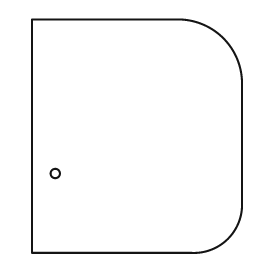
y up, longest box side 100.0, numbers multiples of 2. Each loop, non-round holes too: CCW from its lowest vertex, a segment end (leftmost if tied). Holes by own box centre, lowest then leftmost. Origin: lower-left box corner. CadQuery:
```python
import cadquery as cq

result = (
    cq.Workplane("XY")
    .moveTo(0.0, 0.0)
    .lineTo(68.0, 0.0)
    .threePointArc((84.0, 6.0), (90.0, 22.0))
    .lineTo(90.0, 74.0)
    .threePointArc((82.0, 92.0), (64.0, 100.0))
    .lineTo(0.0, 100.0)
    .close()
    .moveTo(10.0, 34.0)
    .circle(2.0)
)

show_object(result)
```